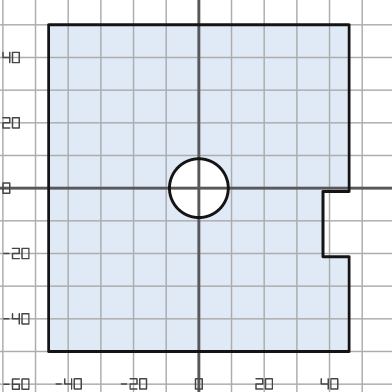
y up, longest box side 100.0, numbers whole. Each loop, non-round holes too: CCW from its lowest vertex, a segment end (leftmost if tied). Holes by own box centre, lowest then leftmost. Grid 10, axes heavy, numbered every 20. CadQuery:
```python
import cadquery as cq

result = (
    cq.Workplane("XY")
    .moveTo(-46.0, -50.0)
    .lineTo(46.0, -50.0)
    .lineTo(46.0, -21.0)
    .lineTo(38.0, -21.0)
    .lineTo(38.0, -1.0)
    .lineTo(46.0, -1.0)
    .lineTo(46.0, 50.0)
    .lineTo(-46.0, 50.0)
    .close()
    .moveTo(0.0, 0.0)
    .circle(9.0)
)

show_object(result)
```